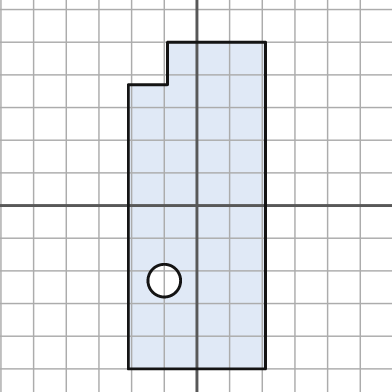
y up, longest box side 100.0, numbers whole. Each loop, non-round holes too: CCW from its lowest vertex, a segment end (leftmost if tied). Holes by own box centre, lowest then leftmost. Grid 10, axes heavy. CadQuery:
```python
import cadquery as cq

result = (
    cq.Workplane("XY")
    .moveTo(-21.0, -50.0)
    .lineTo(21.0, -50.0)
    .lineTo(21.0, 50.0)
    .lineTo(-9.0, 50.0)
    .lineTo(-9.0, 37.0)
    .lineTo(-21.0, 37.0)
    .close()
    .moveTo(-10.0, -23.0)
    .circle(5.0)
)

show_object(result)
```